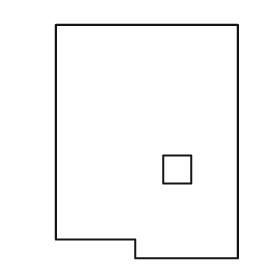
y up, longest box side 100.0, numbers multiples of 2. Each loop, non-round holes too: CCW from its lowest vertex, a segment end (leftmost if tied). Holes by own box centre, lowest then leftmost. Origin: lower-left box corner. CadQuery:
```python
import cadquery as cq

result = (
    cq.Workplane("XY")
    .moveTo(34.0, 0.0)
    .lineTo(78.0, 0.0)
    .lineTo(78.0, 100.0)
    .lineTo(0.0, 100.0)
    .lineTo(0.0, 8.0)
    .lineTo(34.0, 8.0)
    .close()
    .moveTo(46.0, 32.0)
    .lineTo(58.0, 32.0)
    .lineTo(58.0, 44.0)
    .lineTo(46.0, 44.0)
    .close()
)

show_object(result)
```